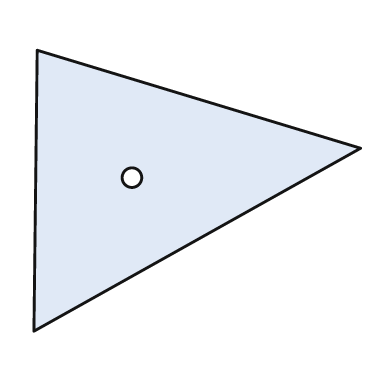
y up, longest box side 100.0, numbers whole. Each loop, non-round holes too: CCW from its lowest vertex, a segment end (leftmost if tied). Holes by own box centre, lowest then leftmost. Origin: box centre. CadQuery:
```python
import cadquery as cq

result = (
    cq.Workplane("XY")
    .moveTo(-50.0, -43.0)
    .lineTo(50.0, 13.0)
    .lineTo(-49.0, 43.0)
    .close()
    .moveTo(-20.0, 4.0)
    .circle(3.0)
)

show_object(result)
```